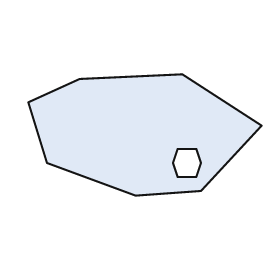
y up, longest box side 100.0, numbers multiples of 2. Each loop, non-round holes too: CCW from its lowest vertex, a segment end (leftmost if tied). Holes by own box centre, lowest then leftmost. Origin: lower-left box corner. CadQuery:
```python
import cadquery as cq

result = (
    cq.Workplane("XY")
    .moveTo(46.0, 0.0)
    .lineTo(74.0, 2.0)
    .lineTo(100.0, 30.0)
    .lineTo(66.0, 52.0)
    .lineTo(22.0, 50.0)
    .lineTo(0.0, 40.0)
    .lineTo(8.0, 14.0)
    .close()
    .moveTo(64.0, 8.0)
    .lineTo(72.0, 8.0)
    .lineTo(74.0, 14.0)
    .lineTo(72.0, 20.0)
    .lineTo(64.0, 20.0)
    .lineTo(62.0, 14.0)
    .close()
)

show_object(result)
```